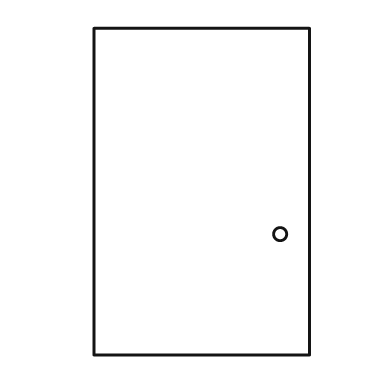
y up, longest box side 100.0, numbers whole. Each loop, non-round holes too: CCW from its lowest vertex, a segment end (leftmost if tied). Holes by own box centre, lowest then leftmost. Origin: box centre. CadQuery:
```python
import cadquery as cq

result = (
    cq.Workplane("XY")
    .moveTo(-33.0, -50.0)
    .lineTo(33.0, -50.0)
    .lineTo(33.0, 50.0)
    .lineTo(-33.0, 50.0)
    .close()
    .moveTo(24.0, -13.0)
    .circle(2.0)
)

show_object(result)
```